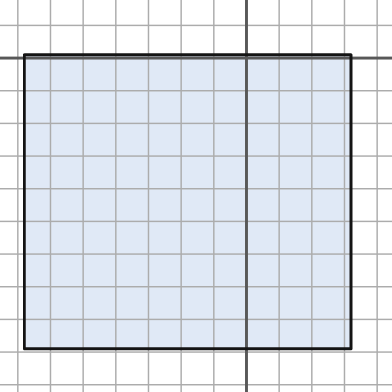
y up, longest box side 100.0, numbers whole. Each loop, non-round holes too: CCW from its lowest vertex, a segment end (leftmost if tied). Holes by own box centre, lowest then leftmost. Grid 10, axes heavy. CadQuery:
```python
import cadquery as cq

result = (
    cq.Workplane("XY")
    .moveTo(-68.0, -89.0)
    .lineTo(32.0, -89.0)
    .lineTo(32.0, 1.0)
    .lineTo(-68.0, 1.0)
    .close()
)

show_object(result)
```